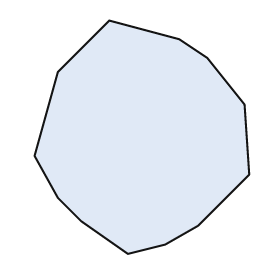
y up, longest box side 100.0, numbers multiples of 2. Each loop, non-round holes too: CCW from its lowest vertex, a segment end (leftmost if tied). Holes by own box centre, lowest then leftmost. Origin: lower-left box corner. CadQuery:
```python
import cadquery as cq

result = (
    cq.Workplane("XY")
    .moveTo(40.0, 0.0)
    .lineTo(56.0, 4.0)
    .lineTo(70.0, 12.0)
    .lineTo(92.0, 34.0)
    .lineTo(90.0, 64.0)
    .lineTo(74.0, 84.0)
    .lineTo(62.0, 92.0)
    .lineTo(32.0, 100.0)
    .lineTo(10.0, 78.0)
    .lineTo(0.0, 42.0)
    .lineTo(10.0, 24.0)
    .lineTo(20.0, 14.0)
    .close()
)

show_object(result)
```